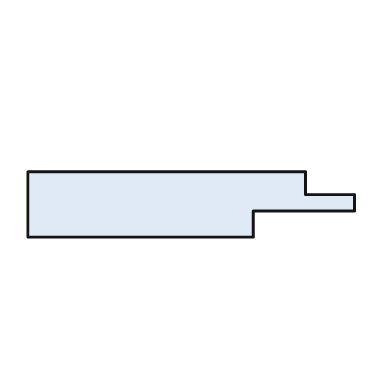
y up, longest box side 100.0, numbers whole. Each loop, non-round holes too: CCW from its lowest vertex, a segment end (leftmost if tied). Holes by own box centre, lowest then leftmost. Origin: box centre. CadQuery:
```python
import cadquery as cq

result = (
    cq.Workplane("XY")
    .moveTo(-50.0, -10.0)
    .lineTo(19.0, -10.0)
    .lineTo(19.0, -2.0)
    .lineTo(50.0, -2.0)
    .lineTo(50.0, 3.0)
    .lineTo(35.0, 3.0)
    .lineTo(35.0, 10.0)
    .lineTo(-50.0, 10.0)
    .close()
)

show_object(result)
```